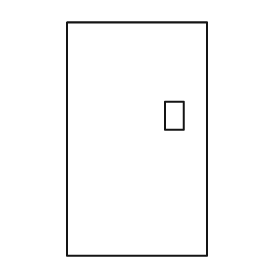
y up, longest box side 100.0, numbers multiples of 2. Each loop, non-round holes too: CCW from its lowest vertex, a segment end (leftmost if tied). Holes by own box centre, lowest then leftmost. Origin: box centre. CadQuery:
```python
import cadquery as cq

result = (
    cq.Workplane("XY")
    .moveTo(-30.0, -50.0)
    .lineTo(30.0, -50.0)
    .lineTo(30.0, 50.0)
    .lineTo(-30.0, 50.0)
    .close()
    .moveTo(12.0, 4.0)
    .lineTo(20.0, 4.0)
    .lineTo(20.0, 16.0)
    .lineTo(12.0, 16.0)
    .close()
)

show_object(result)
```